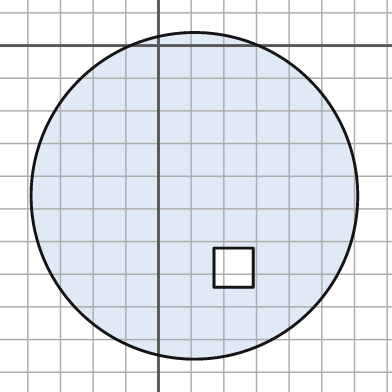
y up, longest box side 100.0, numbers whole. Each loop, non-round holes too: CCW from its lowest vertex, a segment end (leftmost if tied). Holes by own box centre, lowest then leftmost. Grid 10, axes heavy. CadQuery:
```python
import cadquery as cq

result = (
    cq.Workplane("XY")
    .moveTo(11.0, -46.0)
    .circle(50.0)
    .moveTo(17.0, -74.0)
    .lineTo(29.0, -74.0)
    .lineTo(29.0, -62.0)
    .lineTo(17.0, -62.0)
    .close()
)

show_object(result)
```